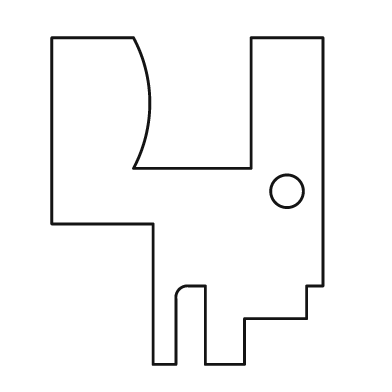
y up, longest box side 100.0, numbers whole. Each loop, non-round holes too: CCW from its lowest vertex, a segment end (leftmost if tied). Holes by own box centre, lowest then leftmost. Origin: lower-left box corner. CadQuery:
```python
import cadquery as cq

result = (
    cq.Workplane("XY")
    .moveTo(31.0, 0.0)
    .lineTo(38.0, 0.0)
    .lineTo(38.0, 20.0)
    .threePointArc((39.0, 23.0), (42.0, 24.0))
    .lineTo(47.0, 24.0)
    .lineTo(47.0, 0.0)
    .lineTo(59.0, 0.0)
    .lineTo(59.0, 14.0)
    .lineTo(78.0, 14.0)
    .lineTo(78.0, 24.0)
    .lineTo(83.0, 24.0)
    .lineTo(83.0, 100.0)
    .lineTo(61.0, 100.0)
    .lineTo(61.0, 60.0)
    .lineTo(25.0, 60.0)
    .threePointArc((30.0, 80.0), (25.0, 100.0))
    .lineTo(0.0, 100.0)
    .lineTo(0.0, 43.0)
    .lineTo(31.0, 43.0)
    .close()
    .moveTo(72.0, 53.0)
    .circle(5.0)
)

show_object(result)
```